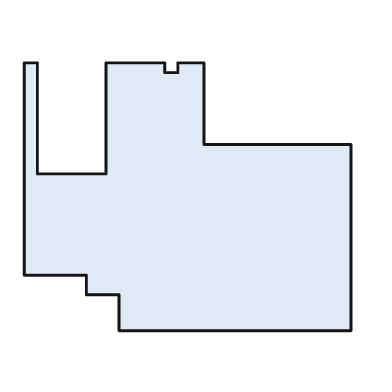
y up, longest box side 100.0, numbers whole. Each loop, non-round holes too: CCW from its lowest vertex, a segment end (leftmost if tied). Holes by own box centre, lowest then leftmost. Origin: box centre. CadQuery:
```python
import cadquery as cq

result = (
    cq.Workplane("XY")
    .moveTo(-21.0, -41.0)
    .lineTo(50.0, -41.0)
    .lineTo(50.0, 16.0)
    .lineTo(5.0, 16.0)
    .lineTo(5.0, 41.0)
    .lineTo(-3.0, 41.0)
    .lineTo(-3.0, 38.0)
    .lineTo(-7.0, 38.0)
    .lineTo(-7.0, 41.0)
    .lineTo(-25.0, 41.0)
    .lineTo(-25.0, 7.0)
    .lineTo(-46.0, 7.0)
    .lineTo(-46.0, 41.0)
    .lineTo(-50.0, 41.0)
    .lineTo(-50.0, -24.0)
    .lineTo(-31.0, -24.0)
    .lineTo(-31.0, -30.0)
    .lineTo(-21.0, -30.0)
    .close()
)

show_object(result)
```